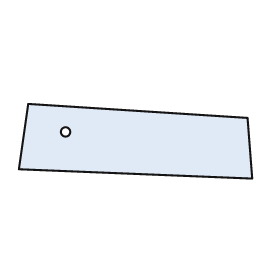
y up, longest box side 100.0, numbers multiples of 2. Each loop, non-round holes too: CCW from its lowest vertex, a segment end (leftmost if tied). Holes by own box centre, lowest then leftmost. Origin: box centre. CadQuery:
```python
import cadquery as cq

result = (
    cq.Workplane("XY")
    .moveTo(50.0, -16.0)
    .lineTo(48.0, 10.0)
    .lineTo(-46.0, 16.0)
    .lineTo(-50.0, -12.0)
    .close()
    .moveTo(-30.0, 4.0)
    .circle(2.0)
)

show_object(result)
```